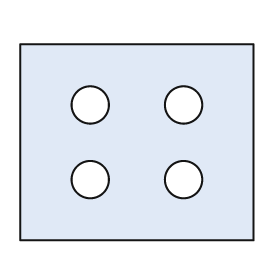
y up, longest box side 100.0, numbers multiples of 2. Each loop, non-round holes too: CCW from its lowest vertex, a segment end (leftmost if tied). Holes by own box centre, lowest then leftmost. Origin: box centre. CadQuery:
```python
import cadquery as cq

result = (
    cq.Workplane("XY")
    .moveTo(-50.0, -42.0)
    .lineTo(50.0, -42.0)
    .lineTo(50.0, 42.0)
    .lineTo(-50.0, 42.0)
    .close()
    .moveTo(-20.0, -16.0)
    .circle(8.0)
    .moveTo(20.0, -16.0)
    .circle(8.0)
    .moveTo(-20.0, 16.0)
    .circle(8.0)
    .moveTo(20.0, 16.0)
    .circle(8.0)
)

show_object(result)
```